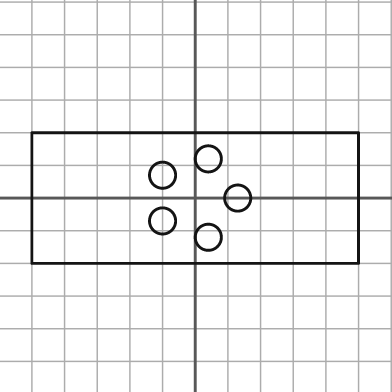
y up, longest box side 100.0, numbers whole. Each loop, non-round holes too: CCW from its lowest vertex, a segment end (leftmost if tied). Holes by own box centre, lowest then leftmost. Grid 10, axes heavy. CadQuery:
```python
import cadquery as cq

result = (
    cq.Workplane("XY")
    .moveTo(-50.0, -20.0)
    .lineTo(50.0, -20.0)
    .lineTo(50.0, 20.0)
    .lineTo(-50.0, 20.0)
    .close()
    .moveTo(4.0, -12.0)
    .circle(4.0)
    .moveTo(-10.0, -7.0)
    .circle(4.0)
    .moveTo(13.0, 0.0)
    .circle(4.0)
    .moveTo(-10.0, 7.0)
    .circle(4.0)
    .moveTo(4.0, 12.0)
    .circle(4.0)
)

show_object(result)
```